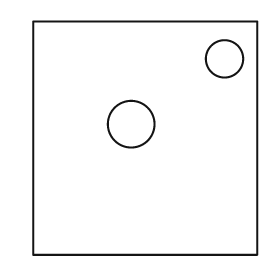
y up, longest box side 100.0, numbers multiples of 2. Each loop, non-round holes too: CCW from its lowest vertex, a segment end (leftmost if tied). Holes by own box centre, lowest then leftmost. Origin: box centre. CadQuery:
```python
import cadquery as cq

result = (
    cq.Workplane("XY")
    .moveTo(-48.0, -50.0)
    .lineTo(48.0, -50.0)
    .lineTo(48.0, 50.0)
    .lineTo(-48.0, 50.0)
    .close()
    .moveTo(-6.0, 6.0)
    .circle(10.0)
    .moveTo(34.0, 34.0)
    .circle(8.0)
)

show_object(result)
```